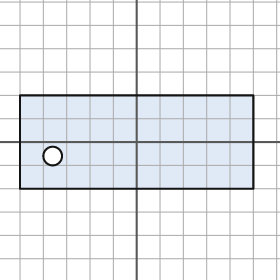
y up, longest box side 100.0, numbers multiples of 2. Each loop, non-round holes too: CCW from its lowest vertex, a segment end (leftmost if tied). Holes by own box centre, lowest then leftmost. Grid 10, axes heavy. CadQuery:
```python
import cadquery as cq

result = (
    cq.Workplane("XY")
    .moveTo(-50.0, -20.0)
    .lineTo(50.0, -20.0)
    .lineTo(50.0, 20.0)
    .lineTo(-50.0, 20.0)
    .close()
    .moveTo(-36.0, -6.0)
    .circle(4.0)
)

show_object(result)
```